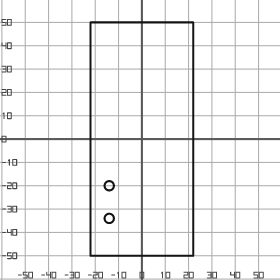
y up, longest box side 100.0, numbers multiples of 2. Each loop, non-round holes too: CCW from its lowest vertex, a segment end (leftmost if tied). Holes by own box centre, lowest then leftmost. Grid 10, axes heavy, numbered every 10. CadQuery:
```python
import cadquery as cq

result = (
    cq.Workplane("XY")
    .moveTo(-22.0, -50.0)
    .lineTo(22.0, -50.0)
    .lineTo(22.0, 50.0)
    .lineTo(-22.0, 50.0)
    .close()
    .moveTo(-14.0, -34.0)
    .circle(2.0)
    .moveTo(-14.0, -20.0)
    .circle(2.0)
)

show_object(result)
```